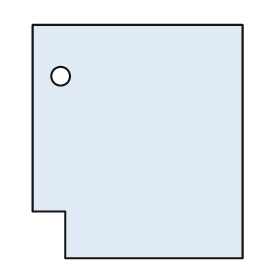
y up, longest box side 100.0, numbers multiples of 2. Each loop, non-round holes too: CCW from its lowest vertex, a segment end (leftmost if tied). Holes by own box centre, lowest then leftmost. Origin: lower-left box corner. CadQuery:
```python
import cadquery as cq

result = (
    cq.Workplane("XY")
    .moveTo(14.0, 0.0)
    .lineTo(90.0, 0.0)
    .lineTo(90.0, 100.0)
    .lineTo(0.0, 100.0)
    .lineTo(0.0, 20.0)
    .lineTo(14.0, 20.0)
    .close()
    .moveTo(12.0, 78.0)
    .circle(4.0)
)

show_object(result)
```